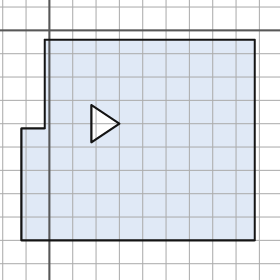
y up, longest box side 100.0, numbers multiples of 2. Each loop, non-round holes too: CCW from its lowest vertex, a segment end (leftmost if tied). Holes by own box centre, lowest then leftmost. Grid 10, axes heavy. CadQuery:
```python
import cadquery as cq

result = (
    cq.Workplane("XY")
    .moveTo(-12.0, -90.0)
    .lineTo(88.0, -90.0)
    .lineTo(88.0, -4.0)
    .lineTo(-2.0, -4.0)
    .lineTo(-2.0, -42.0)
    .lineTo(-12.0, -42.0)
    .close()
    .moveTo(18.0, -48.0)
    .lineTo(30.0, -40.0)
    .lineTo(18.0, -32.0)
    .close()
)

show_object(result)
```